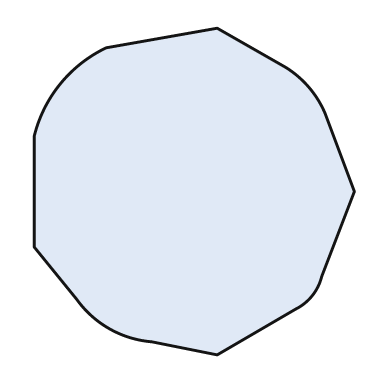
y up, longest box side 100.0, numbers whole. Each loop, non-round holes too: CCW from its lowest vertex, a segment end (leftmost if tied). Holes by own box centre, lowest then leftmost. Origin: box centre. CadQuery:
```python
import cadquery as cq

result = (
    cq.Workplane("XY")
    .moveTo(7.0, -50.0)
    .lineTo(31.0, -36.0)
    .threePointArc((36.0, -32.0), (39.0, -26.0))
    .lineTo(49.0, 0.0)
    .lineTo(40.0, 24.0)
    .threePointArc((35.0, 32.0), (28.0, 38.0))
    .lineTo(7.0, 50.0)
    .lineTo(-27.0, 44.0)
    .threePointArc((-41.0, 33.0), (-49.0, 17.0))
    .lineTo(-49.0, -17.0)
    .lineTo(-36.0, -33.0)
    .threePointArc((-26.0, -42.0), (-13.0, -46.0))
    .close()
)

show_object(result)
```